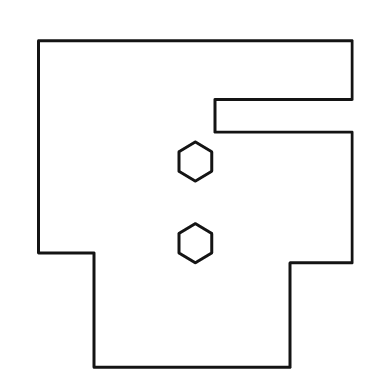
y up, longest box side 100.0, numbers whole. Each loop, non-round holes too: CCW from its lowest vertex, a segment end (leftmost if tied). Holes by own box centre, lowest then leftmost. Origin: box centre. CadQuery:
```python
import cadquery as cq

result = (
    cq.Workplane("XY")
    .moveTo(-31.0, -50.0)
    .lineTo(29.0, -50.0)
    .lineTo(29.0, -18.0)
    .lineTo(48.0, -18.0)
    .lineTo(48.0, 22.0)
    .lineTo(6.0, 22.0)
    .lineTo(6.0, 32.0)
    .lineTo(48.0, 32.0)
    .lineTo(48.0, 50.0)
    .lineTo(-48.0, 50.0)
    .lineTo(-48.0, -15.0)
    .lineTo(-31.0, -15.0)
    .close()
    .moveTo(0.0, -18.0)
    .lineTo(5.0, -15.0)
    .lineTo(5.0, -9.0)
    .lineTo(0.0, -6.0)
    .lineTo(-5.0, -9.0)
    .lineTo(-5.0, -15.0)
    .close()
    .moveTo(0.0, 7.0)
    .lineTo(5.0, 10.0)
    .lineTo(5.0, 16.0)
    .lineTo(0.0, 19.0)
    .lineTo(-5.0, 16.0)
    .lineTo(-5.0, 10.0)
    .close()
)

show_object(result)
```